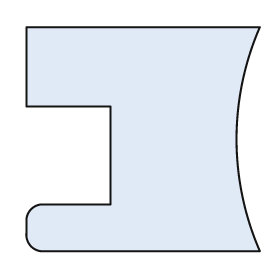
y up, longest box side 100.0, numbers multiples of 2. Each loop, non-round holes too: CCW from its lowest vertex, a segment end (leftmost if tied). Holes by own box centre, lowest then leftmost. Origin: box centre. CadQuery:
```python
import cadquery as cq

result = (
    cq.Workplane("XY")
    .moveTo(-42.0, -48.0)
    .lineTo(50.0, -48.0)
    .threePointArc((40.0, 0.0), (50.0, 48.0))
    .lineTo(-50.0, 48.0)
    .lineTo(-50.0, 14.0)
    .lineTo(-14.0, 14.0)
    .lineTo(-14.0, -28.0)
    .lineTo(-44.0, -28.0)
    .threePointArc((-48.0, -30.0), (-50.0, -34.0))
    .lineTo(-50.0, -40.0)
    .threePointArc((-48.0, -46.0), (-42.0, -48.0))
    .close()
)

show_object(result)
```